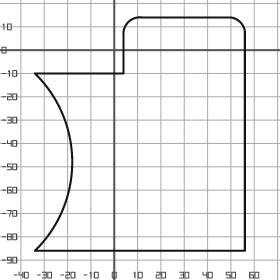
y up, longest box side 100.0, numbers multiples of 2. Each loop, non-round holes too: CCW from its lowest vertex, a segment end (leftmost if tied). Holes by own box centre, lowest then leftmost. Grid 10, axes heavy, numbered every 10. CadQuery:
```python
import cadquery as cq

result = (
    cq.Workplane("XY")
    .moveTo(-34.0, -86.0)
    .lineTo(56.0, -86.0)
    .lineTo(56.0, 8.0)
    .threePointArc((54.0, 12.0), (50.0, 14.0))
    .lineTo(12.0, 14.0)
    .threePointArc((6.0, 12.0), (4.0, 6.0))
    .lineTo(4.0, -10.0)
    .lineTo(-34.0, -10.0)
    .threePointArc((-18.0, -48.0), (-34.0, -86.0))
    .close()
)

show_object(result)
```